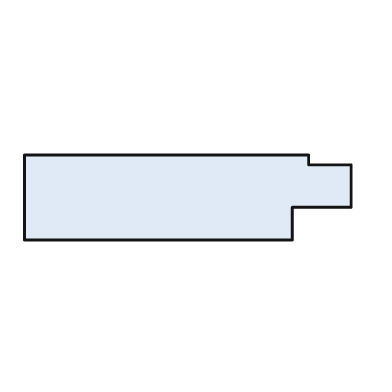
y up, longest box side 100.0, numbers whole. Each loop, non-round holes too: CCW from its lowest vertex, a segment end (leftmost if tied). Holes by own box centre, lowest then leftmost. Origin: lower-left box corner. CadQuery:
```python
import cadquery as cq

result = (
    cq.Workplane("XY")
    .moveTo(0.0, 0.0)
    .lineTo(82.0, 0.0)
    .lineTo(82.0, 10.0)
    .lineTo(100.0, 10.0)
    .lineTo(100.0, 23.0)
    .lineTo(87.0, 23.0)
    .lineTo(87.0, 26.0)
    .lineTo(0.0, 26.0)
    .close()
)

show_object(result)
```